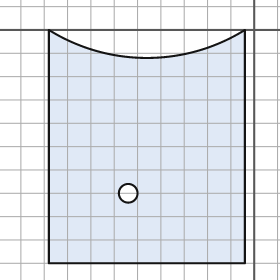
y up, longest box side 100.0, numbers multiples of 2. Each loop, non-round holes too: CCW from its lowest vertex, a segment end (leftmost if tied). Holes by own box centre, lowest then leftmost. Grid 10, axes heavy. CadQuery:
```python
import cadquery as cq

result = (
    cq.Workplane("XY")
    .moveTo(-88.0, -100.0)
    .lineTo(-4.0, -100.0)
    .lineTo(-4.0, 0.0)
    .threePointArc((-46.0, -12.0), (-88.0, 0.0))
    .close()
    .moveTo(-54.0, -70.0)
    .circle(4.0)
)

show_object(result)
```